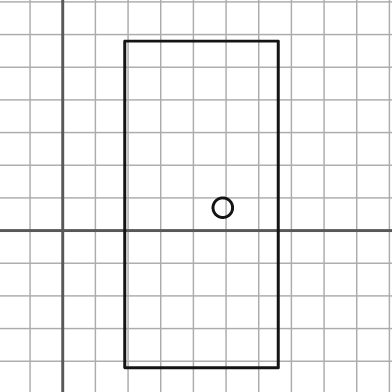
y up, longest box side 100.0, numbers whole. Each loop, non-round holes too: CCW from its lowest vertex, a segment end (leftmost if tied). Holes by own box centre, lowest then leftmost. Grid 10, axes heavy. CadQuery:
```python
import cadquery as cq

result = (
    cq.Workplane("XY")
    .moveTo(19.0, -42.0)
    .lineTo(66.0, -42.0)
    .lineTo(66.0, 58.0)
    .lineTo(19.0, 58.0)
    .close()
    .moveTo(49.0, 7.0)
    .circle(3.0)
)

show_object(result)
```